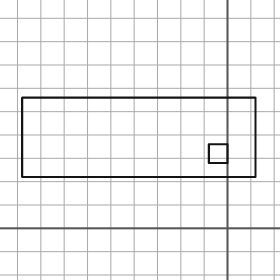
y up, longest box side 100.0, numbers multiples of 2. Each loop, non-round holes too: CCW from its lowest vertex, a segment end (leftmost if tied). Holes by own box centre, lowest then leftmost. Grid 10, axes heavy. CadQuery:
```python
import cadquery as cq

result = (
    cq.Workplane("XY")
    .moveTo(-88.0, 22.0)
    .lineTo(12.0, 22.0)
    .lineTo(12.0, 56.0)
    .lineTo(-88.0, 56.0)
    .close()
    .moveTo(-8.0, 28.0)
    .lineTo(0.0, 28.0)
    .lineTo(0.0, 36.0)
    .lineTo(-8.0, 36.0)
    .close()
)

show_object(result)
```